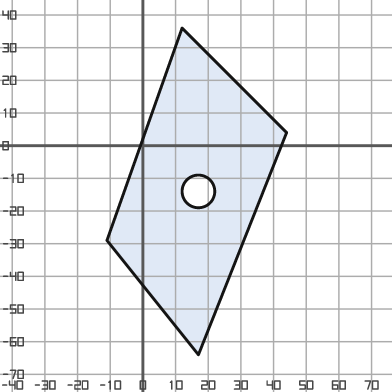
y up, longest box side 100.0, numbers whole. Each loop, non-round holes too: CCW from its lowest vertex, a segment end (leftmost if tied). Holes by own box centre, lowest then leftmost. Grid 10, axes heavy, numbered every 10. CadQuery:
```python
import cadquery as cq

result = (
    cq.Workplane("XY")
    .moveTo(17.0, -64.0)
    .lineTo(44.0, 4.0)
    .lineTo(12.0, 36.0)
    .lineTo(-11.0, -29.0)
    .close()
    .moveTo(17.0, -14.0)
    .circle(5.0)
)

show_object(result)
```